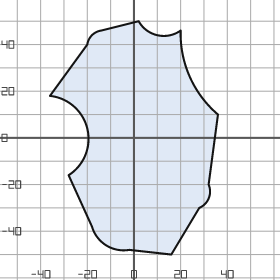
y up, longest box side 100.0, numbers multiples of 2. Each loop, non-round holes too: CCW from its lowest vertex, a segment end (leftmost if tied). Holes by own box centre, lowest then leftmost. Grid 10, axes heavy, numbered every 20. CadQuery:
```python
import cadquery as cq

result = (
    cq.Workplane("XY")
    .moveTo(16.0, -50.0)
    .lineTo(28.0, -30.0)
    .threePointArc((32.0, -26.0), (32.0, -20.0))
    .lineTo(36.0, 10.0)
    .threePointArc((24.0, 26.0), (20.0, 46.0))
    .threePointArc((10.0, 44.0), (2.0, 50.0))
    .lineTo(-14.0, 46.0)
    .threePointArc((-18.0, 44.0), (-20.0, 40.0))
    .lineTo(-36.0, 18.0)
    .threePointArc((-20.0, 4.0), (-28.0, -16.0))
    .lineTo(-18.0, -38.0)
    .threePointArc((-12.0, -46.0), (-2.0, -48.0))
    .close()
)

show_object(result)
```